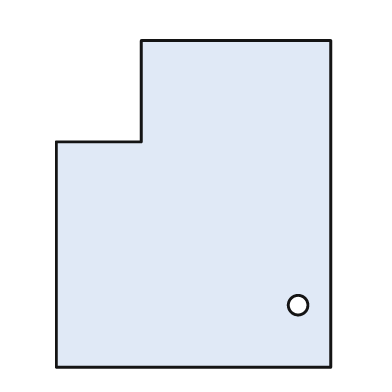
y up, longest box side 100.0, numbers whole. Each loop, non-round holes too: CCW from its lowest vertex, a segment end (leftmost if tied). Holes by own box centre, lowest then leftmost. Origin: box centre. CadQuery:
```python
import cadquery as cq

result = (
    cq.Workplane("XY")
    .moveTo(-42.0, -50.0)
    .lineTo(42.0, -50.0)
    .lineTo(42.0, 50.0)
    .lineTo(-16.0, 50.0)
    .lineTo(-16.0, 19.0)
    .lineTo(-42.0, 19.0)
    .close()
    .moveTo(32.0, -31.0)
    .circle(3.0)
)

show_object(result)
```